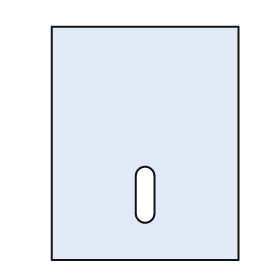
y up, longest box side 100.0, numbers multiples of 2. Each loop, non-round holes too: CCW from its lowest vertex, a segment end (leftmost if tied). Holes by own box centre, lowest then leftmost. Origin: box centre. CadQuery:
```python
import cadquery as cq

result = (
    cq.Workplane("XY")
    .moveTo(-40.0, -50.0)
    .lineTo(40.0, -50.0)
    .lineTo(40.0, 50.0)
    .lineTo(-40.0, 50.0)
    .close()
    .moveTo(-4.0, -30.0)
    .threePointArc((0.0, -34.0), (4.0, -30.0))
    .lineTo(4.0, -14.0)
    .threePointArc((0.0, -10.0), (-4.0, -14.0))
    .close()
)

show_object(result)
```